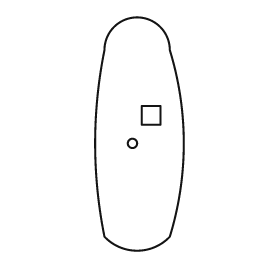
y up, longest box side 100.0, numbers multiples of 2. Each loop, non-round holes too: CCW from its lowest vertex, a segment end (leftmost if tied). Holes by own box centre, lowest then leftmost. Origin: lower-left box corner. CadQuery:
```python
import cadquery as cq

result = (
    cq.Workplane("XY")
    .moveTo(4.0, 6.0)
    .threePointArc((18.0, 0.0), (32.0, 6.0))
    .threePointArc((38.0, 46.0), (32.0, 86.0))
    .threePointArc((18.0, 100.0), (4.0, 86.0))
    .threePointArc((0.0, 46.0), (4.0, 6.0))
    .close()
    .moveTo(16.0, 46.0)
    .circle(2.0)
    .moveTo(20.0, 54.0)
    .lineTo(28.0, 54.0)
    .lineTo(28.0, 62.0)
    .lineTo(20.0, 62.0)
    .close()
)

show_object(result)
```